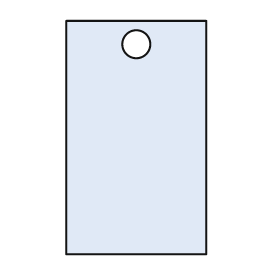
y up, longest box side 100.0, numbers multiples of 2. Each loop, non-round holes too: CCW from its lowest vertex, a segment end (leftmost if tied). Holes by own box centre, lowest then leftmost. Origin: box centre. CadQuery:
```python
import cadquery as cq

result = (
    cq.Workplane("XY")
    .moveTo(-30.0, -50.0)
    .lineTo(30.0, -50.0)
    .lineTo(30.0, 50.0)
    .lineTo(-30.0, 50.0)
    .close()
    .moveTo(0.0, 40.0)
    .circle(6.0)
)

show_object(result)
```